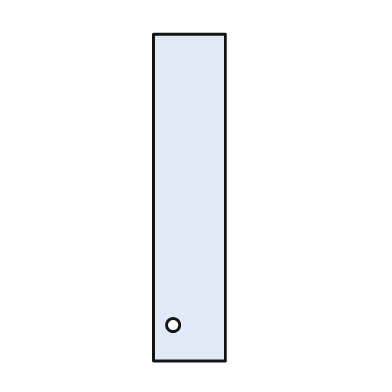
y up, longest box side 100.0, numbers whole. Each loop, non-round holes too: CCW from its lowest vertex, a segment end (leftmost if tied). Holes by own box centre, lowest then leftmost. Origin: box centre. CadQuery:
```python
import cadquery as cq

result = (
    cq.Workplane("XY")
    .moveTo(-11.0, -50.0)
    .lineTo(11.0, -50.0)
    .lineTo(11.0, 50.0)
    .lineTo(-11.0, 50.0)
    .close()
    .moveTo(-5.0, -39.0)
    .circle(2.0)
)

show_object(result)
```